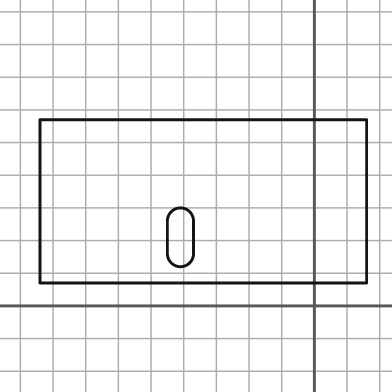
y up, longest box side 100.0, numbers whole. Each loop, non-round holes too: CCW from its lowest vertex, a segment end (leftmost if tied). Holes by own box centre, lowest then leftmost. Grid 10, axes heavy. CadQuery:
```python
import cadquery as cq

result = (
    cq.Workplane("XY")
    .moveTo(-84.0, 7.0)
    .lineTo(16.0, 7.0)
    .lineTo(16.0, 57.0)
    .lineTo(-84.0, 57.0)
    .close()
    .moveTo(-45.0, 16.0)
    .threePointArc((-41.0, 12.0), (-37.0, 16.0))
    .lineTo(-37.0, 26.0)
    .threePointArc((-41.0, 30.0), (-45.0, 26.0))
    .close()
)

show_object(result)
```